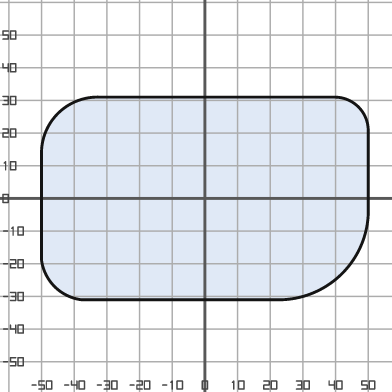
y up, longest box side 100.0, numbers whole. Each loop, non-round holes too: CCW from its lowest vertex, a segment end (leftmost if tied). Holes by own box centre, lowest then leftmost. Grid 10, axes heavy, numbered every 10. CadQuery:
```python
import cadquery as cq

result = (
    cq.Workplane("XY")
    .moveTo(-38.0, -31.0)
    .lineTo(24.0, -31.0)
    .threePointArc((42.0, -23.0), (50.0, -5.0))
    .lineTo(50.0, 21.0)
    .threePointArc((47.0, 28.0), (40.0, 31.0))
    .lineTo(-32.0, 31.0)
    .threePointArc((-45.0, 26.0), (-50.0, 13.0))
    .lineTo(-50.0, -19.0)
    .threePointArc((-46.0, -27.0), (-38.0, -31.0))
    .close()
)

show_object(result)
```